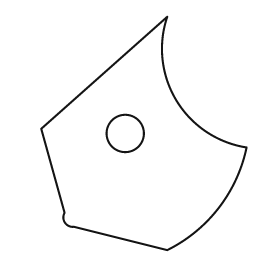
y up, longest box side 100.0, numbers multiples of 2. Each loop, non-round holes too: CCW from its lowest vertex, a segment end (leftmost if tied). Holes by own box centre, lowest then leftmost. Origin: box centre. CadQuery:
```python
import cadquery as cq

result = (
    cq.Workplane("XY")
    .moveTo(10.0, -50.0)
    .threePointArc((32.0, -32.0), (44.0, -6.0))
    .threePointArc((14.0, 14.0), (10.0, 50.0))
    .lineTo(-44.0, 2.0)
    .lineTo(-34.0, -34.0)
    .threePointArc((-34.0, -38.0), (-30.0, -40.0))
    .close()
    .moveTo(-8.0, 0.0)
    .circle(8.0)
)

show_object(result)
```